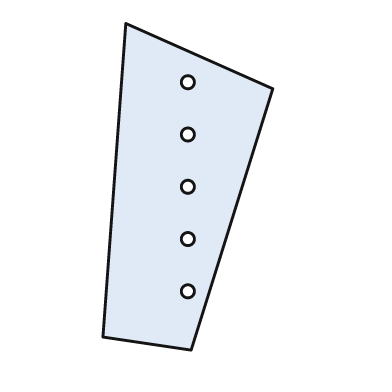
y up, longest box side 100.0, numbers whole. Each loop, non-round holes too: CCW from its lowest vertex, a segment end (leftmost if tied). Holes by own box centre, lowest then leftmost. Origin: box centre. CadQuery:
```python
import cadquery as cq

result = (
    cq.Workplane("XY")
    .moveTo(1.0, -50.0)
    .lineTo(26.0, 30.0)
    .lineTo(-19.0, 50.0)
    .lineTo(-26.0, -46.0)
    .close()
    .moveTo(0.0, -32.0)
    .circle(2.0)
    .moveTo(0.0, -16.0)
    .circle(2.0)
    .moveTo(0.0, 0.0)
    .circle(2.0)
    .moveTo(0.0, 16.0)
    .circle(2.0)
    .moveTo(0.0, 32.0)
    .circle(2.0)
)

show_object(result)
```